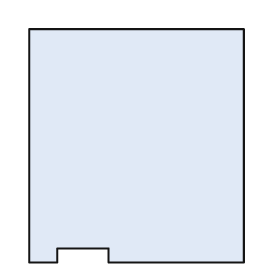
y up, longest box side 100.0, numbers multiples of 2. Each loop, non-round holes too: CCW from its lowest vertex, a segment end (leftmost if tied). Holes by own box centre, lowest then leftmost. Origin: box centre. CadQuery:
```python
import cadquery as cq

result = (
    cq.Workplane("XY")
    .moveTo(-46.0, -50.0)
    .lineTo(-34.0, -50.0)
    .lineTo(-34.0, -44.0)
    .lineTo(-12.0, -44.0)
    .lineTo(-12.0, -50.0)
    .lineTo(46.0, -50.0)
    .lineTo(46.0, 50.0)
    .lineTo(-46.0, 50.0)
    .close()
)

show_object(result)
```